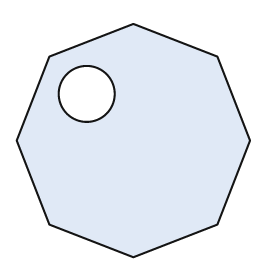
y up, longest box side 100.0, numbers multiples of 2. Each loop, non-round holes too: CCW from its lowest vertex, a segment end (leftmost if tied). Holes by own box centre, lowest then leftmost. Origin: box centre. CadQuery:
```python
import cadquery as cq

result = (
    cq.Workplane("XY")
    .moveTo(0.0, -50.0)
    .lineTo(36.0, -36.0)
    .lineTo(50.0, 0.0)
    .lineTo(36.0, 36.0)
    .lineTo(0.0, 50.0)
    .lineTo(-36.0, 36.0)
    .lineTo(-50.0, 0.0)
    .lineTo(-36.0, -36.0)
    .close()
    .moveTo(-20.0, 20.0)
    .circle(12.0)
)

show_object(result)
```